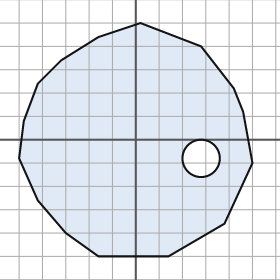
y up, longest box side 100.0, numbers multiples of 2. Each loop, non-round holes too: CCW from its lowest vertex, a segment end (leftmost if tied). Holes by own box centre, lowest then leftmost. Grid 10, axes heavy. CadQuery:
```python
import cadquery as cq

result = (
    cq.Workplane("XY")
    .moveTo(-16.0, -50.0)
    .lineTo(14.0, -50.0)
    .lineTo(38.0, -36.0)
    .lineTo(50.0, -10.0)
    .lineTo(46.0, 12.0)
    .lineTo(42.0, 22.0)
    .lineTo(28.0, 40.0)
    .lineTo(2.0, 50.0)
    .lineTo(-16.0, 44.0)
    .lineTo(-32.0, 34.0)
    .lineTo(-42.0, 24.0)
    .lineTo(-48.0, 8.0)
    .lineTo(-50.0, -8.0)
    .lineTo(-42.0, -26.0)
    .lineTo(-30.0, -40.0)
    .close()
    .moveTo(28.0, -8.0)
    .circle(8.0)
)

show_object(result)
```